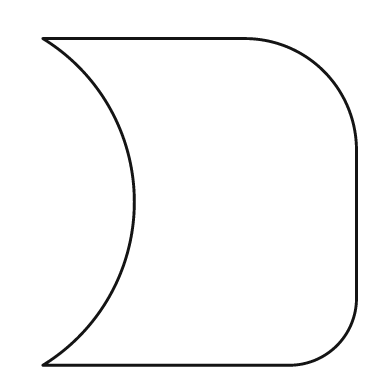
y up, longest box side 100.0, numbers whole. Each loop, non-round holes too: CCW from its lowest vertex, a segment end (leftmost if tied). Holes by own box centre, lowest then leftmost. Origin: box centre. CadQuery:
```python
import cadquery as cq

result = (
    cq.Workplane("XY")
    .moveTo(-48.0, -50.0)
    .lineTo(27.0, -50.0)
    .threePointArc((42.0, -44.0), (48.0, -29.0))
    .lineTo(48.0, 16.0)
    .threePointArc((38.0, 40.0), (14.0, 50.0))
    .lineTo(-48.0, 50.0)
    .threePointArc((-20.0, 0.0), (-48.0, -50.0))
    .close()
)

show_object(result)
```